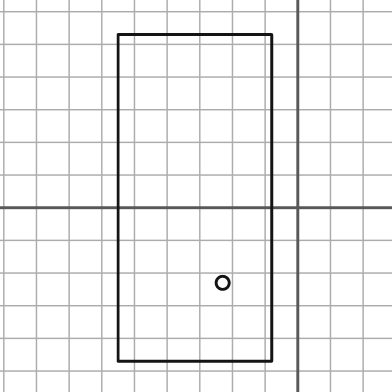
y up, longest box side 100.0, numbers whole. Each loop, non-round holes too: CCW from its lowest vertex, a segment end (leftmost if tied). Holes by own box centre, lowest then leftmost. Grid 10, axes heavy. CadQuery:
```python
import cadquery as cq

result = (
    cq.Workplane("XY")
    .moveTo(-55.0, -47.0)
    .lineTo(-8.0, -47.0)
    .lineTo(-8.0, 53.0)
    .lineTo(-55.0, 53.0)
    .close()
    .moveTo(-23.0, -23.0)
    .circle(2.0)
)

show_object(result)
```